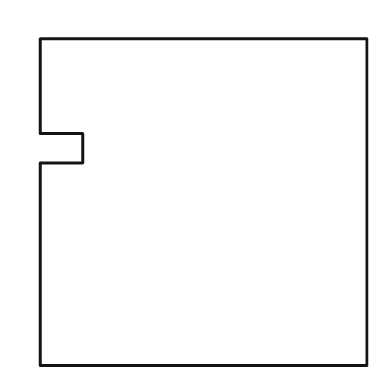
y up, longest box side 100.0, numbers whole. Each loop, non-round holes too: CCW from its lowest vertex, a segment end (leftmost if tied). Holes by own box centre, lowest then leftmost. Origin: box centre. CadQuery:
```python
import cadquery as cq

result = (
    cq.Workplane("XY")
    .moveTo(-50.0, -50.0)
    .lineTo(50.0, -50.0)
    .lineTo(50.0, 50.0)
    .lineTo(-50.0, 50.0)
    .lineTo(-50.0, 21.0)
    .lineTo(-37.0, 21.0)
    .lineTo(-37.0, 12.0)
    .lineTo(-50.0, 12.0)
    .close()
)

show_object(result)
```